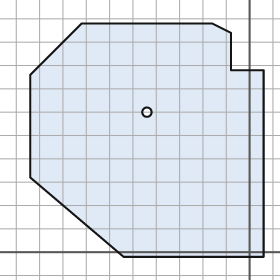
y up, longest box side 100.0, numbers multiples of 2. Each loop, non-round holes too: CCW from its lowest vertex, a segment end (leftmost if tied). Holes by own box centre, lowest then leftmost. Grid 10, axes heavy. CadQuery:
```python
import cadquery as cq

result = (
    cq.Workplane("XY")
    .moveTo(-54.0, -2.0)
    .lineTo(6.0, -2.0)
    .lineTo(6.0, 78.0)
    .lineTo(-8.0, 78.0)
    .lineTo(-8.0, 94.0)
    .lineTo(-16.0, 98.0)
    .lineTo(-72.0, 98.0)
    .lineTo(-94.0, 76.0)
    .lineTo(-94.0, 32.0)
    .close()
    .moveTo(-44.0, 60.0)
    .circle(2.0)
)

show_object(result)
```